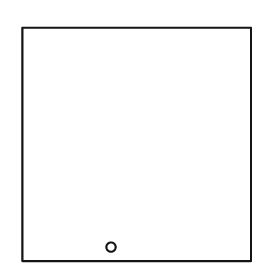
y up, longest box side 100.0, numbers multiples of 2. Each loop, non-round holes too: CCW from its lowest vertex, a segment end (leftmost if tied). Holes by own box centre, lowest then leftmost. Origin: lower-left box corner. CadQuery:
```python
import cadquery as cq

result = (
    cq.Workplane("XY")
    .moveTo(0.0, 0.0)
    .lineTo(98.0, 0.0)
    .lineTo(98.0, 100.0)
    .lineTo(0.0, 100.0)
    .close()
    .moveTo(38.0, 6.0)
    .circle(2.0)
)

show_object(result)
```